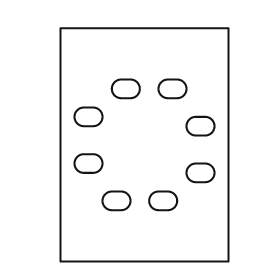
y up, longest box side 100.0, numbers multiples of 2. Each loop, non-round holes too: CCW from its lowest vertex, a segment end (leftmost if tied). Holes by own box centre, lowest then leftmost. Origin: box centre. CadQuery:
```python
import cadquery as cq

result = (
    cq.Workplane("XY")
    .moveTo(-36.0, -50.0)
    .lineTo(36.0, -50.0)
    .lineTo(36.0, 50.0)
    .lineTo(-36.0, 50.0)
    .close()
    .moveTo(-14.0, -28.0)
    .lineTo(-10.0, -28.0)
    .threePointArc((-6.0, -24.0), (-10.0, -20.0))
    .lineTo(-14.0, -20.0)
    .threePointArc((-18.0, -24.0), (-14.0, -28.0))
    .close()
    .moveTo(6.0, -28.0)
    .lineTo(10.0, -28.0)
    .threePointArc((14.0, -24.0), (10.0, -20.0))
    .lineTo(6.0, -20.0)
    .threePointArc((2.0, -24.0), (6.0, -28.0))
    .close()
    .moveTo(22.0, -16.0)
    .lineTo(26.0, -16.0)
    .threePointArc((30.0, -12.0), (26.0, -8.0))
    .lineTo(22.0, -8.0)
    .threePointArc((18.0, -12.0), (22.0, -16.0))
    .close()
    .moveTo(-26.0, -12.0)
    .lineTo(-22.0, -12.0)
    .threePointArc((-18.0, -8.0), (-22.0, -4.0))
    .lineTo(-26.0, -4.0)
    .threePointArc((-30.0, -8.0), (-26.0, -12.0))
    .close()
    .moveTo(22.0, 4.0)
    .lineTo(26.0, 4.0)
    .threePointArc((30.0, 8.0), (26.0, 12.0))
    .lineTo(22.0, 12.0)
    .threePointArc((18.0, 8.0), (22.0, 4.0))
    .close()
    .moveTo(-26.0, 8.0)
    .lineTo(-22.0, 8.0)
    .threePointArc((-18.0, 12.0), (-22.0, 16.0))
    .lineTo(-26.0, 16.0)
    .threePointArc((-30.0, 12.0), (-26.0, 8.0))
    .close()
    .moveTo(-10.0, 20.0)
    .lineTo(-6.0, 20.0)
    .threePointArc((-2.0, 24.0), (-6.0, 28.0))
    .lineTo(-10.0, 28.0)
    .threePointArc((-14.0, 24.0), (-10.0, 20.0))
    .close()
    .moveTo(10.0, 20.0)
    .lineTo(14.0, 20.0)
    .threePointArc((18.0, 24.0), (14.0, 28.0))
    .lineTo(10.0, 28.0)
    .threePointArc((6.0, 24.0), (10.0, 20.0))
    .close()
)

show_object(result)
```